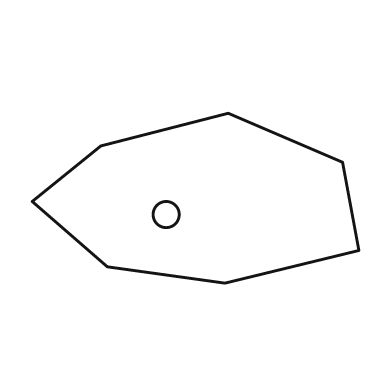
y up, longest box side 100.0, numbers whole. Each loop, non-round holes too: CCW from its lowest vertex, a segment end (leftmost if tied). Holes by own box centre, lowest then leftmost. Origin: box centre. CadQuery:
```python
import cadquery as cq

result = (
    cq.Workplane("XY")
    .moveTo(9.0, -26.0)
    .lineTo(50.0, -16.0)
    .lineTo(45.0, 11.0)
    .lineTo(10.0, 26.0)
    .lineTo(-29.0, 16.0)
    .lineTo(-50.0, -1.0)
    .lineTo(-27.0, -21.0)
    .close()
    .moveTo(-9.0, -5.0)
    .circle(4.0)
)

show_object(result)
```